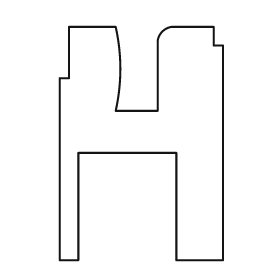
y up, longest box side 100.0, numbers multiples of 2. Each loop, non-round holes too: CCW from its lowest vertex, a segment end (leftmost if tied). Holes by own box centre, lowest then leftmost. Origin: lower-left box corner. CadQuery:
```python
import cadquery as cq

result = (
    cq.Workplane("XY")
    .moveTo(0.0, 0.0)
    .lineTo(8.0, 0.0)
    .lineTo(8.0, 46.0)
    .lineTo(50.0, 46.0)
    .lineTo(50.0, 0.0)
    .lineTo(70.0, 0.0)
    .lineTo(70.0, 92.0)
    .lineTo(66.0, 92.0)
    .lineTo(66.0, 100.0)
    .lineTo(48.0, 100.0)
    .threePointArc((44.0, 98.0), (42.0, 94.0))
    .lineTo(42.0, 64.0)
    .lineTo(24.0, 64.0)
    .threePointArc((26.0, 82.0), (24.0, 100.0))
    .lineTo(4.0, 100.0)
    .lineTo(4.0, 78.0)
    .lineTo(0.0, 78.0)
    .close()
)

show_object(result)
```